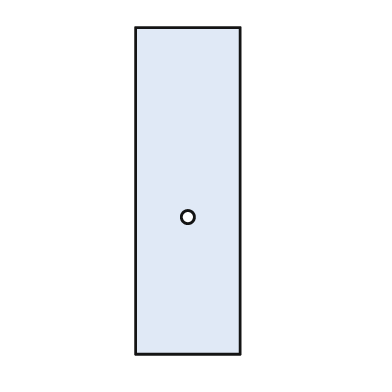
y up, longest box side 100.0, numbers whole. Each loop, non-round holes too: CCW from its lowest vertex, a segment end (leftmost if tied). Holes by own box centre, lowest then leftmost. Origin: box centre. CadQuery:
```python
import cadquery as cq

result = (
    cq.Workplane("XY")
    .moveTo(-16.0, -50.0)
    .lineTo(16.0, -50.0)
    .lineTo(16.0, 50.0)
    .lineTo(-16.0, 50.0)
    .close()
    .moveTo(0.0, -8.0)
    .circle(2.0)
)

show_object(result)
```